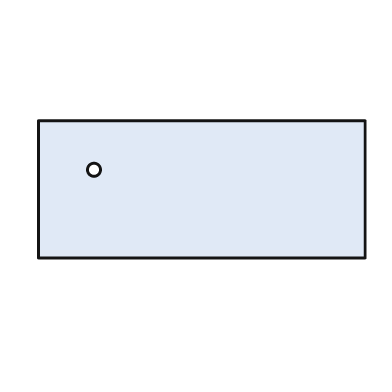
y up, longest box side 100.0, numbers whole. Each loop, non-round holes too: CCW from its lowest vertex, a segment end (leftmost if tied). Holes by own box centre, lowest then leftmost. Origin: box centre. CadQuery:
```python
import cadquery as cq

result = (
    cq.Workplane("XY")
    .moveTo(-50.0, -21.0)
    .lineTo(50.0, -21.0)
    .lineTo(50.0, 21.0)
    .lineTo(-50.0, 21.0)
    .close()
    .moveTo(-33.0, 6.0)
    .circle(2.0)
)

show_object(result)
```